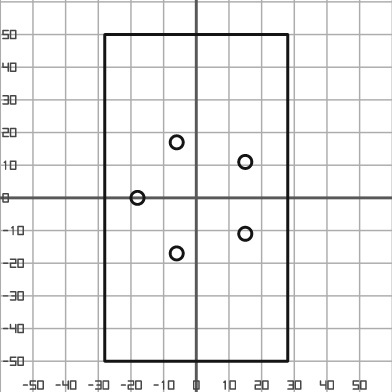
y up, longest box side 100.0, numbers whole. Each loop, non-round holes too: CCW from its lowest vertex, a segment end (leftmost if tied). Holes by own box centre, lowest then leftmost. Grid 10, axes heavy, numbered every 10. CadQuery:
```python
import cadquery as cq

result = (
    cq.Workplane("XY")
    .moveTo(-28.0, -50.0)
    .lineTo(28.0, -50.0)
    .lineTo(28.0, 50.0)
    .lineTo(-28.0, 50.0)
    .close()
    .moveTo(-6.0, -17.0)
    .circle(2.0)
    .moveTo(15.0, -11.0)
    .circle(2.0)
    .moveTo(-18.0, 0.0)
    .circle(2.0)
    .moveTo(15.0, 11.0)
    .circle(2.0)
    .moveTo(-6.0, 17.0)
    .circle(2.0)
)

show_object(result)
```